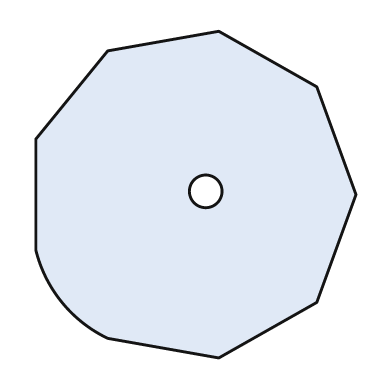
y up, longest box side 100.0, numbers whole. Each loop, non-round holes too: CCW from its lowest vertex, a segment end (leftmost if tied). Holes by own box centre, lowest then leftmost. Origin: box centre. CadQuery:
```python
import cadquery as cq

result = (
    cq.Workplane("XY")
    .moveTo(7.0, -50.0)
    .lineTo(37.0, -33.0)
    .lineTo(49.0, 0.0)
    .lineTo(37.0, 33.0)
    .lineTo(7.0, 50.0)
    .lineTo(-27.0, 44.0)
    .lineTo(-49.0, 17.0)
    .lineTo(-49.0, -17.0)
    .threePointArc((-41.0, -33.0), (-27.0, -44.0))
    .close()
    .moveTo(3.0, 1.0)
    .circle(5.0)
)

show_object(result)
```